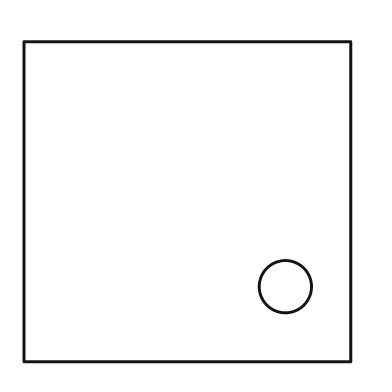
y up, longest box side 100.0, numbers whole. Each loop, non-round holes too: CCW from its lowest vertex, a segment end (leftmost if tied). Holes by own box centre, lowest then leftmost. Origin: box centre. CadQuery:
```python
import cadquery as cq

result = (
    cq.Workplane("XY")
    .moveTo(-50.0, -49.0)
    .lineTo(50.0, -49.0)
    .lineTo(50.0, 49.0)
    .lineTo(-50.0, 49.0)
    .close()
    .moveTo(30.0, -26.0)
    .circle(8.0)
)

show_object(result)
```